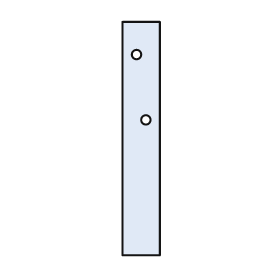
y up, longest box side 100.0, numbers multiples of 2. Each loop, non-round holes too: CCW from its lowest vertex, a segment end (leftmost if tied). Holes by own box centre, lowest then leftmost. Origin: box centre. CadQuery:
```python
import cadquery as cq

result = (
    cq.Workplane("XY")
    .moveTo(-8.0, -50.0)
    .lineTo(8.0, -50.0)
    .lineTo(8.0, 50.0)
    .lineTo(-8.0, 50.0)
    .close()
    .moveTo(2.0, 8.0)
    .circle(2.0)
    .moveTo(-2.0, 36.0)
    .circle(2.0)
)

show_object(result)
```